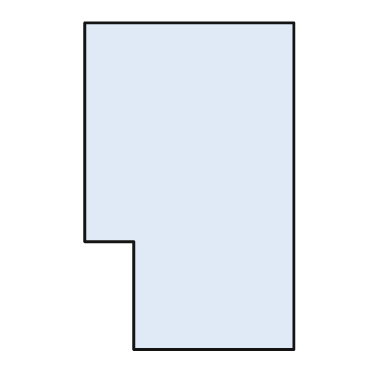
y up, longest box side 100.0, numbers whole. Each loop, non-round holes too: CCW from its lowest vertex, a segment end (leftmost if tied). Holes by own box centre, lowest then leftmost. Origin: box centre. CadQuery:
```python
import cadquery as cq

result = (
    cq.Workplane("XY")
    .moveTo(-17.0, -50.0)
    .lineTo(32.0, -50.0)
    .lineTo(32.0, 50.0)
    .lineTo(-32.0, 50.0)
    .lineTo(-32.0, -17.0)
    .lineTo(-17.0, -17.0)
    .close()
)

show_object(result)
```